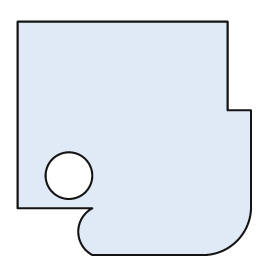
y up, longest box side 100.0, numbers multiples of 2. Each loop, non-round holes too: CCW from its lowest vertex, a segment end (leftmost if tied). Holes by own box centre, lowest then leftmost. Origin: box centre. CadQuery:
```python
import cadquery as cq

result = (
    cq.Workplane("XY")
    .moveTo(-18.0, -50.0)
    .lineTo(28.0, -50.0)
    .threePointArc((44.0, -44.0), (50.0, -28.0))
    .lineTo(50.0, 12.0)
    .lineTo(40.0, 12.0)
    .lineTo(40.0, 50.0)
    .lineTo(-50.0, 50.0)
    .lineTo(-50.0, -30.0)
    .lineTo(-18.0, -30.0)
    .threePointArc((-24.0, -40.0), (-18.0, -50.0))
    .close()
    .moveTo(-28.0, -16.0)
    .circle(10.0)
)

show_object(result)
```